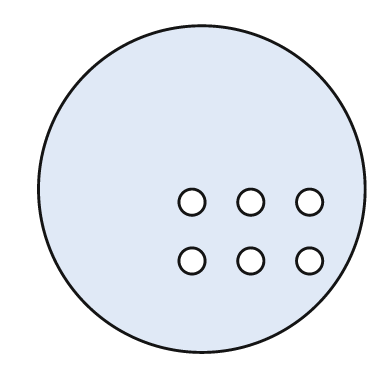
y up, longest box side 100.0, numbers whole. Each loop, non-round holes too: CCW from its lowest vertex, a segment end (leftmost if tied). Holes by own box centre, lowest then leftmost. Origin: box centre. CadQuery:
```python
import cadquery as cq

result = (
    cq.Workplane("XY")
    .moveTo(0.0, 0.0)
    .circle(50.0)
    .moveTo(-3.0, -22.0)
    .circle(4.0)
    .moveTo(15.0, -22.0)
    .circle(4.0)
    .moveTo(33.0, -22.0)
    .circle(4.0)
    .moveTo(-3.0, -4.0)
    .circle(4.0)
    .moveTo(15.0, -4.0)
    .circle(4.0)
    .moveTo(33.0, -4.0)
    .circle(4.0)
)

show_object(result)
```